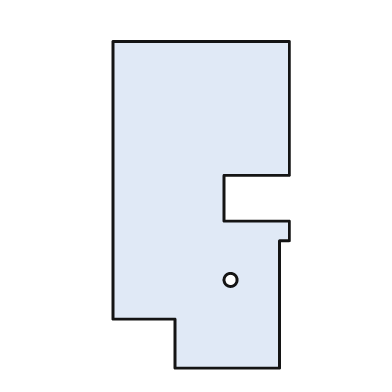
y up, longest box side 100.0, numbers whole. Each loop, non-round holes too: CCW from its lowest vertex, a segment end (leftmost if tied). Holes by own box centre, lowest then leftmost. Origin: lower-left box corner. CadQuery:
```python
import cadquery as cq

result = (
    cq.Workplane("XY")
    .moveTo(19.0, 0.0)
    .lineTo(51.0, 0.0)
    .lineTo(51.0, 39.0)
    .lineTo(54.0, 39.0)
    .lineTo(54.0, 45.0)
    .lineTo(34.0, 45.0)
    .lineTo(34.0, 59.0)
    .lineTo(54.0, 59.0)
    .lineTo(54.0, 100.0)
    .lineTo(0.0, 100.0)
    .lineTo(0.0, 15.0)
    .lineTo(19.0, 15.0)
    .close()
    .moveTo(36.0, 27.0)
    .circle(2.0)
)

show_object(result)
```